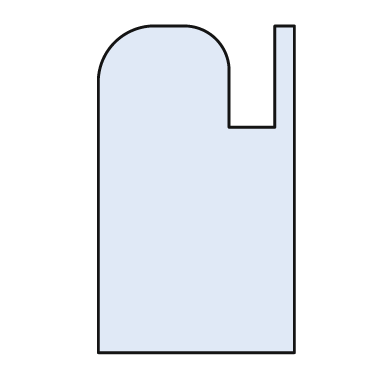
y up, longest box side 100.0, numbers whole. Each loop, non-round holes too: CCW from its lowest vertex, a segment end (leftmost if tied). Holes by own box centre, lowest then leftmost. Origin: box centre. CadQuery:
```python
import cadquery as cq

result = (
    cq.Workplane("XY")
    .moveTo(-30.0, -50.0)
    .lineTo(30.0, -50.0)
    .lineTo(30.0, 50.0)
    .lineTo(24.0, 50.0)
    .lineTo(24.0, 19.0)
    .lineTo(10.0, 19.0)
    .lineTo(10.0, 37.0)
    .threePointArc((6.0, 46.0), (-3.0, 50.0))
    .lineTo(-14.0, 50.0)
    .threePointArc((-25.0, 45.0), (-30.0, 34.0))
    .close()
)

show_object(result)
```